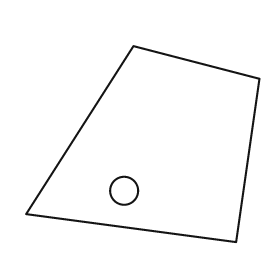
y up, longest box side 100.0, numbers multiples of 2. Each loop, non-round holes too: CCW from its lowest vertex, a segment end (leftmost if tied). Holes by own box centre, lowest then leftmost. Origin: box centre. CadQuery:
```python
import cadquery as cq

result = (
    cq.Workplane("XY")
    .moveTo(40.0, -42.0)
    .lineTo(50.0, 28.0)
    .lineTo(-4.0, 42.0)
    .lineTo(-50.0, -30.0)
    .close()
    .moveTo(-8.0, -20.0)
    .circle(6.0)
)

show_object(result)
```